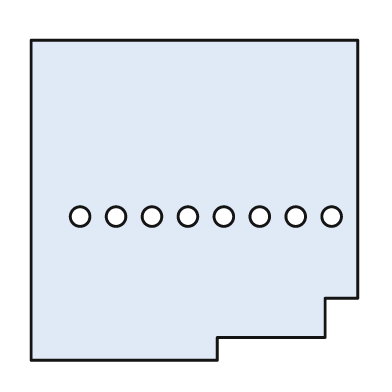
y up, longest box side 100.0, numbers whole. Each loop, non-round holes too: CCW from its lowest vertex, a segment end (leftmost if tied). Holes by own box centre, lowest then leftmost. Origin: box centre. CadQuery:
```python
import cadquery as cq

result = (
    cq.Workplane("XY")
    .moveTo(-50.0, -49.0)
    .lineTo(7.0, -49.0)
    .lineTo(7.0, -42.0)
    .lineTo(40.0, -42.0)
    .lineTo(40.0, -30.0)
    .lineTo(50.0, -30.0)
    .lineTo(50.0, 49.0)
    .lineTo(-50.0, 49.0)
    .close()
    .moveTo(-35.0, -5.0)
    .circle(3.0)
    .moveTo(-24.0, -5.0)
    .circle(3.0)
    .moveTo(-13.0, -5.0)
    .circle(3.0)
    .moveTo(-2.0, -5.0)
    .circle(3.0)
    .moveTo(9.0, -5.0)
    .circle(3.0)
    .moveTo(20.0, -5.0)
    .circle(3.0)
    .moveTo(31.0, -5.0)
    .circle(3.0)
    .moveTo(42.0, -5.0)
    .circle(3.0)
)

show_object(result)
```